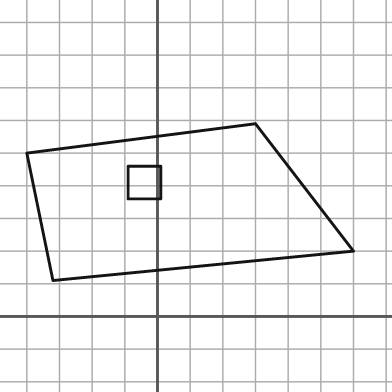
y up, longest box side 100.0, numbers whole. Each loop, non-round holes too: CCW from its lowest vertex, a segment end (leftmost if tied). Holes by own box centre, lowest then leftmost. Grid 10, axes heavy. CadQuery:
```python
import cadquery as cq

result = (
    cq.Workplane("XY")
    .moveTo(-32.0, 11.0)
    .lineTo(60.0, 20.0)
    .lineTo(30.0, 59.0)
    .lineTo(-40.0, 50.0)
    .close()
    .moveTo(-9.0, 36.0)
    .lineTo(1.0, 36.0)
    .lineTo(1.0, 46.0)
    .lineTo(-9.0, 46.0)
    .close()
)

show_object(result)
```